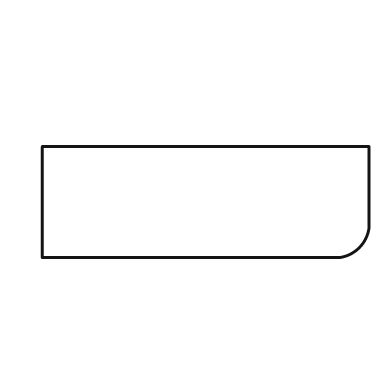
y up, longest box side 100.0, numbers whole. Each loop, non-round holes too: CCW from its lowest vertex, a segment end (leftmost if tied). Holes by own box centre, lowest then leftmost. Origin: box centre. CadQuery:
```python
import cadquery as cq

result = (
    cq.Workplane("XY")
    .moveTo(-50.0, -17.0)
    .lineTo(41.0, -17.0)
    .threePointArc((47.0, -14.0), (50.0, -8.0))
    .lineTo(50.0, 17.0)
    .lineTo(-50.0, 17.0)
    .close()
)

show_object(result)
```